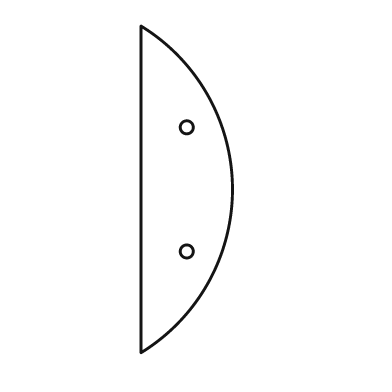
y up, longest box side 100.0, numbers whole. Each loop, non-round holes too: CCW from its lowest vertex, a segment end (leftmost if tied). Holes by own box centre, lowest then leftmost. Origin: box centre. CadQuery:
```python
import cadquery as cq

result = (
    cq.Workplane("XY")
    .moveTo(-14.0, -50.0)
    .threePointArc((14.0, 0.0), (-14.0, 50.0))
    .close()
    .moveTo(0.0, -19.0)
    .circle(2.0)
    .moveTo(0.0, 19.0)
    .circle(2.0)
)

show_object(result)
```